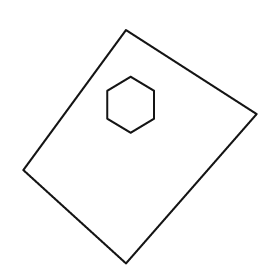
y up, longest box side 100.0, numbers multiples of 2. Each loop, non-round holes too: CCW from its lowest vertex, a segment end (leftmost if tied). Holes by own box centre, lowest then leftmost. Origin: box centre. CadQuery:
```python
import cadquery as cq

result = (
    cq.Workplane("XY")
    .moveTo(-6.0, -50.0)
    .lineTo(50.0, 14.0)
    .lineTo(-6.0, 50.0)
    .lineTo(-50.0, -10.0)
    .close()
    .moveTo(-4.0, 6.0)
    .lineTo(6.0, 12.0)
    .lineTo(6.0, 24.0)
    .lineTo(-4.0, 30.0)
    .lineTo(-14.0, 24.0)
    .lineTo(-14.0, 12.0)
    .close()
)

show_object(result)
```